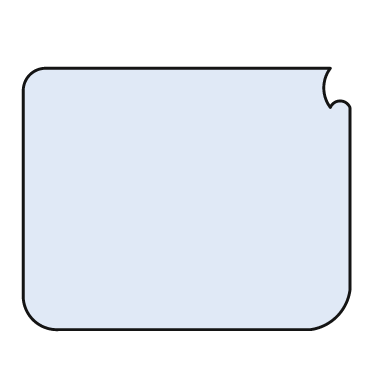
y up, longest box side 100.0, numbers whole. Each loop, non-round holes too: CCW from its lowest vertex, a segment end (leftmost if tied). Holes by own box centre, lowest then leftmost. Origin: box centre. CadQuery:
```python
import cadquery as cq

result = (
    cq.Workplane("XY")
    .moveTo(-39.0, -40.0)
    .lineTo(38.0, -40.0)
    .threePointArc((46.0, -36.0), (50.0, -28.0))
    .lineTo(50.0, 28.0)
    .threePointArc((47.0, 30.0), (44.0, 28.0))
    .threePointArc((42.0, 34.0), (44.0, 40.0))
    .lineTo(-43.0, 40.0)
    .threePointArc((-48.0, 38.0), (-50.0, 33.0))
    .lineTo(-50.0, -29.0)
    .threePointArc((-47.0, -37.0), (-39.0, -40.0))
    .close()
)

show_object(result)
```